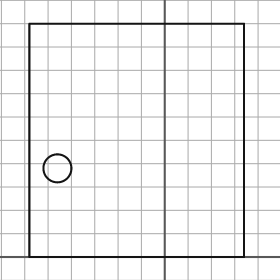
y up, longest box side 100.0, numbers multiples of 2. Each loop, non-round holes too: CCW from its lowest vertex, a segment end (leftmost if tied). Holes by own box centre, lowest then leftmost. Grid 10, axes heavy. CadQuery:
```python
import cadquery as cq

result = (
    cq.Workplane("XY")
    .moveTo(-58.0, 0.0)
    .lineTo(34.0, 0.0)
    .lineTo(34.0, 100.0)
    .lineTo(-58.0, 100.0)
    .close()
    .moveTo(-46.0, 38.0)
    .circle(6.0)
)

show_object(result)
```